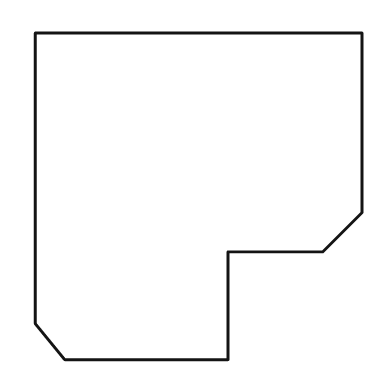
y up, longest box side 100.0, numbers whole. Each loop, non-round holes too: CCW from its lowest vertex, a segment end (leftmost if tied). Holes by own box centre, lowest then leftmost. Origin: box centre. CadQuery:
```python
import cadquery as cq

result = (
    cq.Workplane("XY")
    .moveTo(-41.0, -50.0)
    .lineTo(9.0, -50.0)
    .lineTo(9.0, -17.0)
    .lineTo(38.0, -17.0)
    .lineTo(50.0, -5.0)
    .lineTo(50.0, 50.0)
    .lineTo(-50.0, 50.0)
    .lineTo(-50.0, -39.0)
    .close()
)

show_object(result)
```